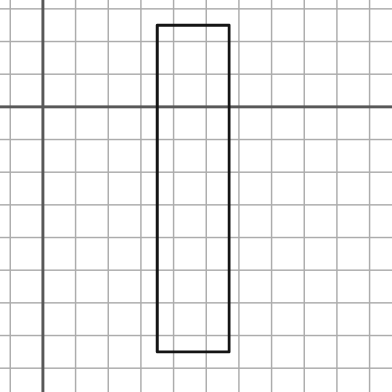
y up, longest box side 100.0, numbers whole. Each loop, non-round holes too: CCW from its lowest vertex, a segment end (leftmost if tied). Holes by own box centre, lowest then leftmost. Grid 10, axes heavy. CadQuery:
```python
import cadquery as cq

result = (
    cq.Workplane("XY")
    .moveTo(35.0, -75.0)
    .lineTo(57.0, -75.0)
    .lineTo(57.0, 25.0)
    .lineTo(35.0, 25.0)
    .close()
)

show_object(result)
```